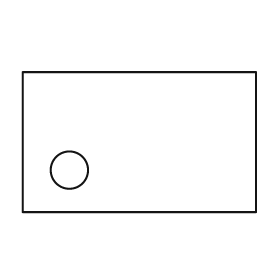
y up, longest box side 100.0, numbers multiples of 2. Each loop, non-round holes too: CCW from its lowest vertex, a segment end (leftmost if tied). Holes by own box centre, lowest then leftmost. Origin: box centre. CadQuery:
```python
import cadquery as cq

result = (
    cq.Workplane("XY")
    .moveTo(-50.0, -30.0)
    .lineTo(50.0, -30.0)
    .lineTo(50.0, 30.0)
    .lineTo(-50.0, 30.0)
    .close()
    .moveTo(-30.0, -12.0)
    .circle(8.0)
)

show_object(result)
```